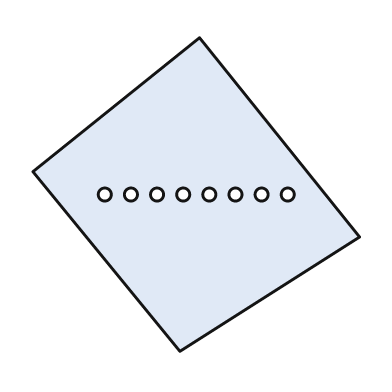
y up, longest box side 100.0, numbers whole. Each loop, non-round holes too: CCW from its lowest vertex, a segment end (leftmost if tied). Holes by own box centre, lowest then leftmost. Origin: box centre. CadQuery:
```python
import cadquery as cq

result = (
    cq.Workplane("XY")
    .moveTo(-5.0, -48.0)
    .lineTo(50.0, -13.0)
    .lineTo(1.0, 48.0)
    .lineTo(-50.0, 7.0)
    .close()
    .moveTo(-28.0, 0.0)
    .circle(2.0)
    .moveTo(-20.0, 0.0)
    .circle(2.0)
    .moveTo(-12.0, 0.0)
    .circle(2.0)
    .moveTo(-4.0, 0.0)
    .circle(2.0)
    .moveTo(4.0, 0.0)
    .circle(2.0)
    .moveTo(12.0, 0.0)
    .circle(2.0)
    .moveTo(20.0, 0.0)
    .circle(2.0)
    .moveTo(28.0, 0.0)
    .circle(2.0)
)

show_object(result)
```